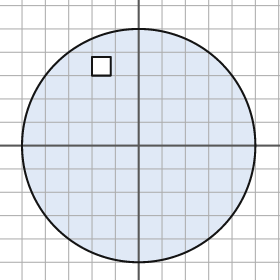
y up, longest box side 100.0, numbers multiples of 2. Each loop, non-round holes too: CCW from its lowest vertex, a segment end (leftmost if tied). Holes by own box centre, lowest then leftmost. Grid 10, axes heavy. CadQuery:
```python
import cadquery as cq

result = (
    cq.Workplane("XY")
    .moveTo(0.0, 0.0)
    .circle(50.0)
    .moveTo(-20.0, 30.0)
    .lineTo(-12.0, 30.0)
    .lineTo(-12.0, 38.0)
    .lineTo(-20.0, 38.0)
    .close()
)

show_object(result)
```